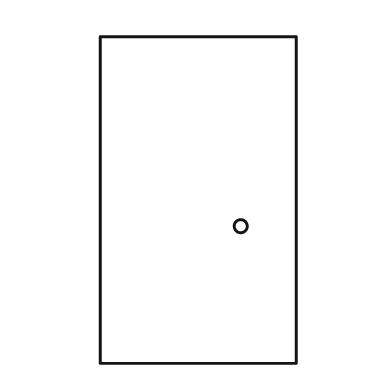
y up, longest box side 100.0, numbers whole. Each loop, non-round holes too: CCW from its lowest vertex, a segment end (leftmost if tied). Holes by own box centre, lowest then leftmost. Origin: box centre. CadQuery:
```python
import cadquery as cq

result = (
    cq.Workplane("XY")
    .moveTo(-30.0, -50.0)
    .lineTo(30.0, -50.0)
    .lineTo(30.0, 50.0)
    .lineTo(-30.0, 50.0)
    .close()
    .moveTo(13.0, -8.0)
    .circle(2.0)
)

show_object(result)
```